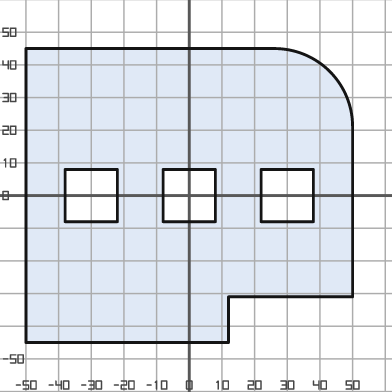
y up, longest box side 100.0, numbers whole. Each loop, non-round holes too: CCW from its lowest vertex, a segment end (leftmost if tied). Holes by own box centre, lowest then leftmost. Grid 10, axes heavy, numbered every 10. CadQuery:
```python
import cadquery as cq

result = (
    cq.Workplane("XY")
    .moveTo(-50.0, -45.0)
    .lineTo(12.0, -45.0)
    .lineTo(12.0, -31.0)
    .lineTo(50.0, -31.0)
    .lineTo(50.0, 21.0)
    .threePointArc((43.0, 38.0), (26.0, 45.0))
    .lineTo(-50.0, 45.0)
    .close()
    .moveTo(-38.0, -8.0)
    .lineTo(-22.0, -8.0)
    .lineTo(-22.0, 8.0)
    .lineTo(-38.0, 8.0)
    .close()
    .moveTo(-8.0, -8.0)
    .lineTo(8.0, -8.0)
    .lineTo(8.0, 8.0)
    .lineTo(-8.0, 8.0)
    .close()
    .moveTo(22.0, -8.0)
    .lineTo(38.0, -8.0)
    .lineTo(38.0, 8.0)
    .lineTo(22.0, 8.0)
    .close()
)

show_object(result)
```